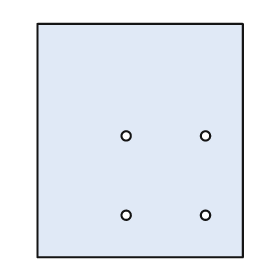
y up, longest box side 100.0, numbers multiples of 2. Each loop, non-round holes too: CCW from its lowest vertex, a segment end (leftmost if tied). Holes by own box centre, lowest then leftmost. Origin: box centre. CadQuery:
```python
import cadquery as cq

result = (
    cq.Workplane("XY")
    .moveTo(-44.0, -50.0)
    .lineTo(44.0, -50.0)
    .lineTo(44.0, 50.0)
    .lineTo(-44.0, 50.0)
    .close()
    .moveTo(-6.0, -32.0)
    .circle(2.0)
    .moveTo(28.0, -32.0)
    .circle(2.0)
    .moveTo(-6.0, 2.0)
    .circle(2.0)
    .moveTo(28.0, 2.0)
    .circle(2.0)
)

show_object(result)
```